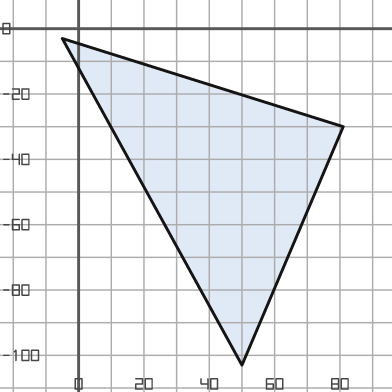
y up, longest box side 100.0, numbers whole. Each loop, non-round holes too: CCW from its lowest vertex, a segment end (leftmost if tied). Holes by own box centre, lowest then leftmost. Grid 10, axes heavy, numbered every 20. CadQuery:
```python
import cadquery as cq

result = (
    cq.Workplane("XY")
    .moveTo(50.0, -103.0)
    .lineTo(81.0, -30.0)
    .lineTo(-5.0, -3.0)
    .close()
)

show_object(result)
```